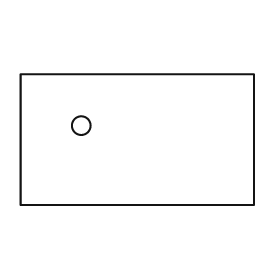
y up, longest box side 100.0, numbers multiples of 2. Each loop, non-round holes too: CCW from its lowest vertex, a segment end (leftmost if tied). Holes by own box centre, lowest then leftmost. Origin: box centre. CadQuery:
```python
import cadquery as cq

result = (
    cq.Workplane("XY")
    .moveTo(-50.0, -28.0)
    .lineTo(50.0, -28.0)
    .lineTo(50.0, 28.0)
    .lineTo(-50.0, 28.0)
    .close()
    .moveTo(-24.0, 6.0)
    .circle(4.0)
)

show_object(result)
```